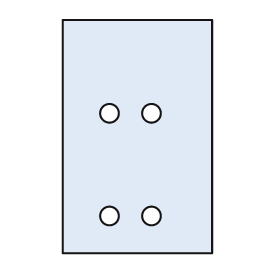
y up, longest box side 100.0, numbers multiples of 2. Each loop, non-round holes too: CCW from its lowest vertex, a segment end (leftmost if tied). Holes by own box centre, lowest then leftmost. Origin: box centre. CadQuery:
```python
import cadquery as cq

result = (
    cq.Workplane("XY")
    .moveTo(-32.0, -50.0)
    .lineTo(32.0, -50.0)
    .lineTo(32.0, 50.0)
    .lineTo(-32.0, 50.0)
    .close()
    .moveTo(-12.0, -34.0)
    .circle(4.0)
    .moveTo(6.0, -34.0)
    .circle(4.0)
    .moveTo(-12.0, 10.0)
    .circle(4.0)
    .moveTo(6.0, 10.0)
    .circle(4.0)
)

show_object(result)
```